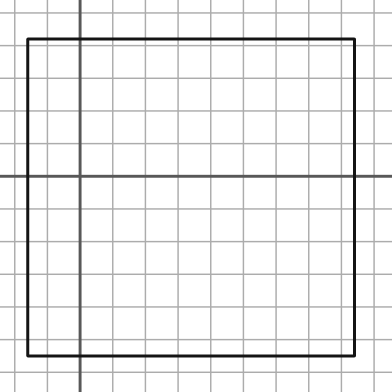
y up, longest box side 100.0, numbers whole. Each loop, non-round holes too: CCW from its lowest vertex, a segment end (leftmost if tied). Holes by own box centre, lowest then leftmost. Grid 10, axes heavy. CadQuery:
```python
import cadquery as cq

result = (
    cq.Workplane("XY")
    .moveTo(-16.0, -55.0)
    .lineTo(84.0, -55.0)
    .lineTo(84.0, 42.0)
    .lineTo(-16.0, 42.0)
    .close()
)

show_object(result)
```